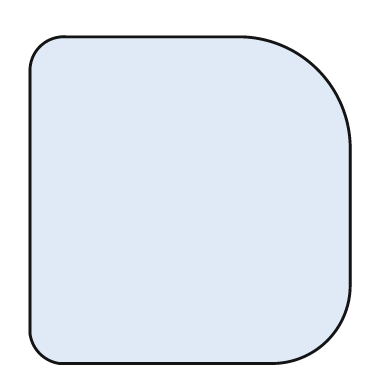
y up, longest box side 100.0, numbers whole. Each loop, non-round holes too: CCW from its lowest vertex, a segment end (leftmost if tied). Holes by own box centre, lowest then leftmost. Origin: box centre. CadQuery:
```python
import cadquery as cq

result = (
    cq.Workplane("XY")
    .moveTo(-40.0, -50.0)
    .lineTo(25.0, -50.0)
    .threePointArc((42.0, -43.0), (49.0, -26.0))
    .lineTo(49.0, 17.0)
    .threePointArc((39.0, 40.0), (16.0, 50.0))
    .lineTo(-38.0, 50.0)
    .threePointArc((-46.0, 47.0), (-49.0, 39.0))
    .lineTo(-49.0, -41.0)
    .threePointArc((-46.0, -47.0), (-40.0, -50.0))
    .close()
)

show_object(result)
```